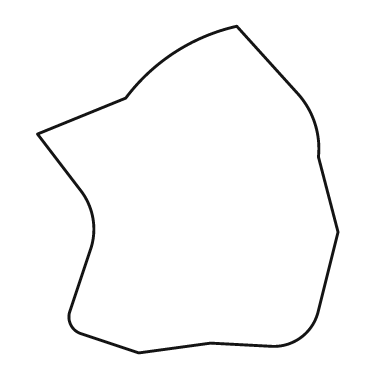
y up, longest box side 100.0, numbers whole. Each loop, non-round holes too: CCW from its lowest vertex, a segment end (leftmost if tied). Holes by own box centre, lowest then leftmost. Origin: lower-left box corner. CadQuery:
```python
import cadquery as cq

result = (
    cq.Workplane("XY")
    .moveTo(31.0, 0.0)
    .lineTo(53.0, 3.0)
    .lineTo(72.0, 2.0)
    .threePointArc((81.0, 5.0), (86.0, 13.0))
    .lineTo(92.0, 37.0)
    .lineTo(86.0, 60.0)
    .threePointArc((85.0, 70.0), (80.0, 79.0))
    .lineTo(61.0, 100.0)
    .threePointArc((42.0, 92.0), (27.0, 78.0))
    .lineTo(0.0, 67.0)
    .lineTo(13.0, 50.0)
    .threePointArc((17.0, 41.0), (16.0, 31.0))
    .lineTo(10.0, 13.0)
    .threePointArc((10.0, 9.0), (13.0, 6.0))
    .close()
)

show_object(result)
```